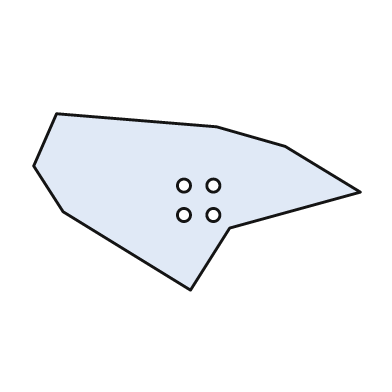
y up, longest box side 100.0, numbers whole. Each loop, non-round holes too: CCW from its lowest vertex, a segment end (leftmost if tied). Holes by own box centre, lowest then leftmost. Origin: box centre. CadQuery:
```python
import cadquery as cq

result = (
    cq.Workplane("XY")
    .moveTo(-2.0, -27.0)
    .lineTo(10.0, -8.0)
    .lineTo(50.0, 3.0)
    .lineTo(27.0, 17.0)
    .lineTo(6.0, 23.0)
    .lineTo(-43.0, 27.0)
    .lineTo(-50.0, 11.0)
    .lineTo(-41.0, -3.0)
    .close()
    .moveTo(-4.0, -4.0)
    .circle(2.0)
    .moveTo(5.0, -4.0)
    .circle(2.0)
    .moveTo(-4.0, 5.0)
    .circle(2.0)
    .moveTo(5.0, 5.0)
    .circle(2.0)
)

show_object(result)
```